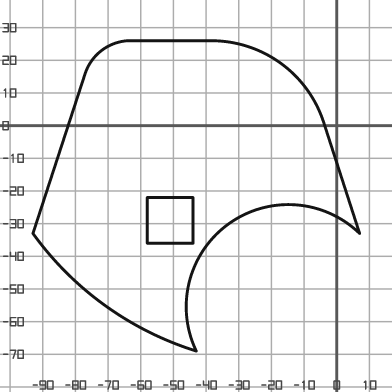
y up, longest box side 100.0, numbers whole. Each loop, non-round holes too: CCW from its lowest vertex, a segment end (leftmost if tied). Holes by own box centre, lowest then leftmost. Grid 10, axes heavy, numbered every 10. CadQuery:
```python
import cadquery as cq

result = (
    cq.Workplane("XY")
    .moveTo(-43.0, -69.0)
    .threePointArc((-33.0, -30.0), (7.0, -33.0))
    .lineTo(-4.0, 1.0)
    .threePointArc((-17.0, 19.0), (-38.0, 26.0))
    .lineTo(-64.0, 26.0)
    .threePointArc((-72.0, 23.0), (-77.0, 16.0))
    .lineTo(-93.0, -33.0)
    .threePointArc((-71.0, -55.0), (-43.0, -69.0))
    .close()
    .moveTo(-58.0, -36.0)
    .lineTo(-44.0, -36.0)
    .lineTo(-44.0, -22.0)
    .lineTo(-58.0, -22.0)
    .close()
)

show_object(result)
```